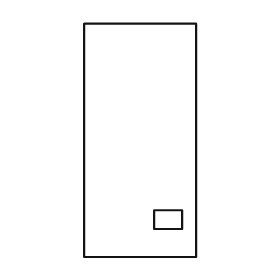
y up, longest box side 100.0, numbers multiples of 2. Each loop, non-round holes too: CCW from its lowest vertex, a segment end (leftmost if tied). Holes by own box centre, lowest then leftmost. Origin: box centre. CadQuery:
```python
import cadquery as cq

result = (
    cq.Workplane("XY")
    .moveTo(-24.0, -50.0)
    .lineTo(24.0, -50.0)
    .lineTo(24.0, 50.0)
    .lineTo(-24.0, 50.0)
    .close()
    .moveTo(6.0, -38.0)
    .lineTo(18.0, -38.0)
    .lineTo(18.0, -30.0)
    .lineTo(6.0, -30.0)
    .close()
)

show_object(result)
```